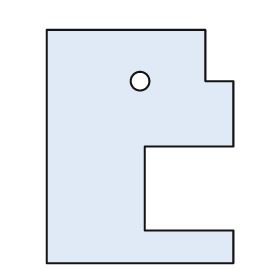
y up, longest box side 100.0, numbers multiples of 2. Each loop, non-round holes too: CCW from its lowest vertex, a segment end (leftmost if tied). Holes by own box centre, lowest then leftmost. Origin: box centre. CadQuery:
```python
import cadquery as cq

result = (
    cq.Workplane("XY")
    .moveTo(-40.0, -50.0)
    .lineTo(40.0, -50.0)
    .lineTo(40.0, -36.0)
    .lineTo(2.0, -36.0)
    .lineTo(2.0, 0.0)
    .lineTo(40.0, 0.0)
    .lineTo(40.0, 28.0)
    .lineTo(28.0, 28.0)
    .lineTo(28.0, 50.0)
    .lineTo(-40.0, 50.0)
    .close()
    .moveTo(0.0, 28.0)
    .circle(4.0)
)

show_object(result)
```